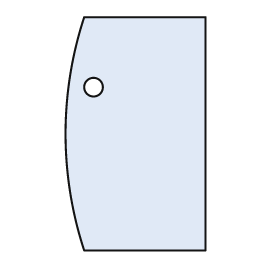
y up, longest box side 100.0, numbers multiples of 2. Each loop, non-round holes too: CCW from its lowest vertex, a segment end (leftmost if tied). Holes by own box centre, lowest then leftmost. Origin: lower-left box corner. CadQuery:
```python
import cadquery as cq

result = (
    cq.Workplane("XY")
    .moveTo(8.0, 0.0)
    .lineTo(60.0, 0.0)
    .lineTo(60.0, 100.0)
    .lineTo(8.0, 100.0)
    .threePointArc((0.0, 50.0), (8.0, 0.0))
    .close()
    .moveTo(12.0, 70.0)
    .circle(4.0)
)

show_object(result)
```